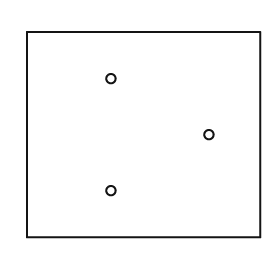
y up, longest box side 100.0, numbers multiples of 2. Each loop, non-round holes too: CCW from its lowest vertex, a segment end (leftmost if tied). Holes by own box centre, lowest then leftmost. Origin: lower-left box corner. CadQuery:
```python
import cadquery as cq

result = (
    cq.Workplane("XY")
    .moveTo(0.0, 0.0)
    .lineTo(100.0, 0.0)
    .lineTo(100.0, 88.0)
    .lineTo(0.0, 88.0)
    .close()
    .moveTo(36.0, 20.0)
    .circle(2.0)
    .moveTo(78.0, 44.0)
    .circle(2.0)
    .moveTo(36.0, 68.0)
    .circle(2.0)
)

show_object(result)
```